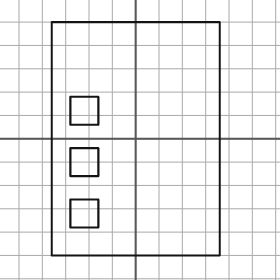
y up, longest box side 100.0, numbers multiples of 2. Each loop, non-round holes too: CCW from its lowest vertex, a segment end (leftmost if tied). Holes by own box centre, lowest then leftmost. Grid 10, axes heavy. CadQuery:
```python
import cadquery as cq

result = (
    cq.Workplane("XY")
    .moveTo(-36.0, -50.0)
    .lineTo(36.0, -50.0)
    .lineTo(36.0, 50.0)
    .lineTo(-36.0, 50.0)
    .close()
    .moveTo(-28.0, -38.0)
    .lineTo(-16.0, -38.0)
    .lineTo(-16.0, -26.0)
    .lineTo(-28.0, -26.0)
    .close()
    .moveTo(-28.0, -16.0)
    .lineTo(-16.0, -16.0)
    .lineTo(-16.0, -4.0)
    .lineTo(-28.0, -4.0)
    .close()
    .moveTo(-28.0, 6.0)
    .lineTo(-16.0, 6.0)
    .lineTo(-16.0, 18.0)
    .lineTo(-28.0, 18.0)
    .close()
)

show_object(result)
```